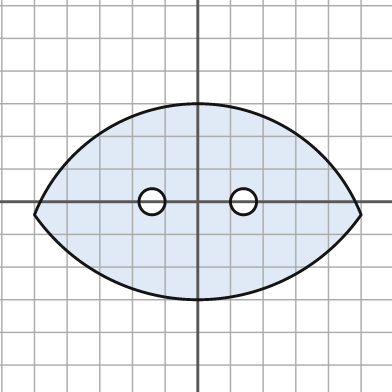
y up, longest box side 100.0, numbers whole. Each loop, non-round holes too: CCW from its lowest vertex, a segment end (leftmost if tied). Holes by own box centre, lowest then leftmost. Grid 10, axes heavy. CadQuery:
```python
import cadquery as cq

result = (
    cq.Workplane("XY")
    .moveTo(-50.0, -4.0)
    .threePointArc((0.0, -30.0), (50.0, -4.0))
    .threePointArc((0.0, 30.0), (-50.0, -4.0))
    .close()
    .moveTo(-14.0, 0.0)
    .circle(4.0)
    .moveTo(14.0, 0.0)
    .circle(4.0)
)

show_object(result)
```